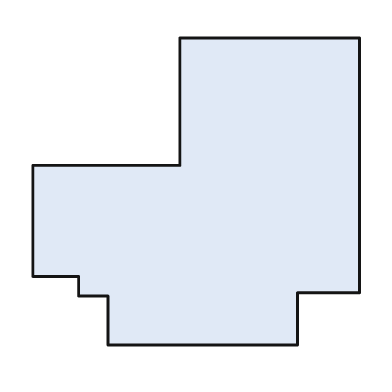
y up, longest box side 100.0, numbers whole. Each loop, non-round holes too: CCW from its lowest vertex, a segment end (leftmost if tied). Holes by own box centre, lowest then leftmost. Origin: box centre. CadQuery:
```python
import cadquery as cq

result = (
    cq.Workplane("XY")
    .moveTo(-27.0, -47.0)
    .lineTo(31.0, -47.0)
    .lineTo(31.0, -31.0)
    .lineTo(50.0, -31.0)
    .lineTo(50.0, 47.0)
    .lineTo(-5.0, 47.0)
    .lineTo(-5.0, 8.0)
    .lineTo(-50.0, 8.0)
    .lineTo(-50.0, -26.0)
    .lineTo(-36.0, -26.0)
    .lineTo(-36.0, -32.0)
    .lineTo(-27.0, -32.0)
    .close()
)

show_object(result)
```